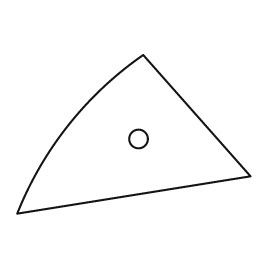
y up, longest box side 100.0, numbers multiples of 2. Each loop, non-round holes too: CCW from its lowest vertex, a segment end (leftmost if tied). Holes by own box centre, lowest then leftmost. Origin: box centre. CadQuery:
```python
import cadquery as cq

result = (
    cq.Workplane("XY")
    .moveTo(-50.0, -34.0)
    .lineTo(50.0, -18.0)
    .lineTo(4.0, 34.0)
    .threePointArc((-28.0, 4.0), (-50.0, -34.0))
    .close()
    .moveTo(2.0, -2.0)
    .circle(4.0)
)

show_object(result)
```